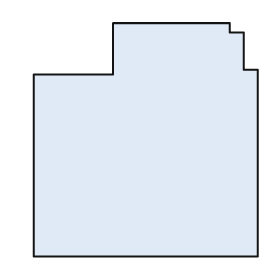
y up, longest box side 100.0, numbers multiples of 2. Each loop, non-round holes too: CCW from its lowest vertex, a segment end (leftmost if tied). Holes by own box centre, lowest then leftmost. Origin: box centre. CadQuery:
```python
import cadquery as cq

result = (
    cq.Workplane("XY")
    .moveTo(-48.0, -50.0)
    .lineTo(48.0, -50.0)
    .lineTo(48.0, 30.0)
    .lineTo(42.0, 30.0)
    .lineTo(42.0, 46.0)
    .lineTo(36.0, 46.0)
    .lineTo(36.0, 50.0)
    .lineTo(-14.0, 50.0)
    .lineTo(-14.0, 28.0)
    .lineTo(-48.0, 28.0)
    .close()
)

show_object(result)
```